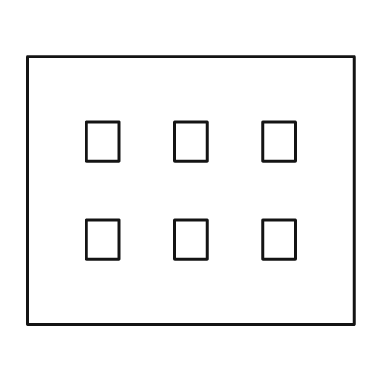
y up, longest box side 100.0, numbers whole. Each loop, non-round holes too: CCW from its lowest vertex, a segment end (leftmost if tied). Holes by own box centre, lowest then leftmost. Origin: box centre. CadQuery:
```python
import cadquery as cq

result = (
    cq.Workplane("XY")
    .moveTo(-50.0, -41.0)
    .lineTo(50.0, -41.0)
    .lineTo(50.0, 41.0)
    .lineTo(-50.0, 41.0)
    .close()
    .moveTo(-32.0, -21.0)
    .lineTo(-22.0, -21.0)
    .lineTo(-22.0, -9.0)
    .lineTo(-32.0, -9.0)
    .close()
    .moveTo(-5.0, -21.0)
    .lineTo(5.0, -21.0)
    .lineTo(5.0, -9.0)
    .lineTo(-5.0, -9.0)
    .close()
    .moveTo(22.0, -21.0)
    .lineTo(32.0, -21.0)
    .lineTo(32.0, -9.0)
    .lineTo(22.0, -9.0)
    .close()
    .moveTo(-32.0, 9.0)
    .lineTo(-22.0, 9.0)
    .lineTo(-22.0, 21.0)
    .lineTo(-32.0, 21.0)
    .close()
    .moveTo(-5.0, 9.0)
    .lineTo(5.0, 9.0)
    .lineTo(5.0, 21.0)
    .lineTo(-5.0, 21.0)
    .close()
    .moveTo(22.0, 9.0)
    .lineTo(32.0, 9.0)
    .lineTo(32.0, 21.0)
    .lineTo(22.0, 21.0)
    .close()
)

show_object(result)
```